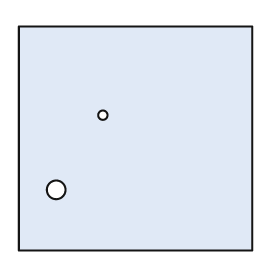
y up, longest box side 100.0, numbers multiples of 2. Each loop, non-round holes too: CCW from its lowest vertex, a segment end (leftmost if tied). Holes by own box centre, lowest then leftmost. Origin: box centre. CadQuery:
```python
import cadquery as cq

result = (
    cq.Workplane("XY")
    .moveTo(-50.0, -48.0)
    .lineTo(50.0, -48.0)
    .lineTo(50.0, 48.0)
    .lineTo(-50.0, 48.0)
    .close()
    .moveTo(-34.0, -22.0)
    .circle(4.0)
    .moveTo(-14.0, 10.0)
    .circle(2.0)
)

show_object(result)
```